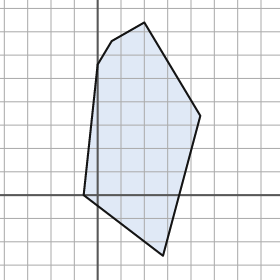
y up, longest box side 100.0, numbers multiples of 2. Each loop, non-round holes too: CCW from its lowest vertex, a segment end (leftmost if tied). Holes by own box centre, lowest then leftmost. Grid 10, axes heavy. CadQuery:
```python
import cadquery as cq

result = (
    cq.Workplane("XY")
    .moveTo(28.0, -26.0)
    .lineTo(44.0, 34.0)
    .lineTo(20.0, 74.0)
    .lineTo(6.0, 66.0)
    .lineTo(0.0, 56.0)
    .lineTo(-6.0, 0.0)
    .close()
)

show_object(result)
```